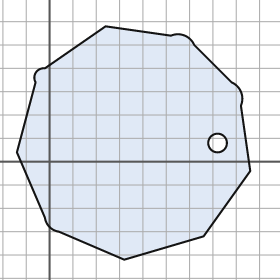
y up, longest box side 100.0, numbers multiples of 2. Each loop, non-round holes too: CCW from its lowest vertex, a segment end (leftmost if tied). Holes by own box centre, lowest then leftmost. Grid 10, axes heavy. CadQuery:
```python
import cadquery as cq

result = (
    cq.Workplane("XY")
    .moveTo(32.0, -42.0)
    .lineTo(66.0, -32.0)
    .lineTo(86.0, -4.0)
    .lineTo(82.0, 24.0)
    .threePointArc((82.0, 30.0), (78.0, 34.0))
    .lineTo(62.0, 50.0)
    .threePointArc((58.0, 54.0), (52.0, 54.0))
    .lineTo(24.0, 58.0)
    .lineTo(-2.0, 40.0)
    .threePointArc((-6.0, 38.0), (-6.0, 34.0))
    .lineTo(-14.0, 4.0)
    .lineTo(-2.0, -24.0)
    .threePointArc((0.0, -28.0), (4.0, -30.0))
    .close()
    .moveTo(72.0, 8.0)
    .circle(4.0)
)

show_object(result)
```